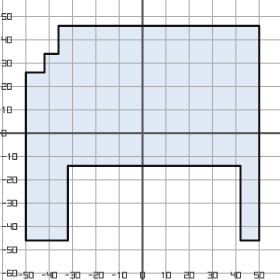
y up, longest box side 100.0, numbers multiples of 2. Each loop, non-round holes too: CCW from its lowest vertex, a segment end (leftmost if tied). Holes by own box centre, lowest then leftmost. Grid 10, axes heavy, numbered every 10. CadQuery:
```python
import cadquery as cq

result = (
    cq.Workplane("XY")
    .moveTo(-50.0, -46.0)
    .lineTo(-32.0, -46.0)
    .lineTo(-32.0, -14.0)
    .lineTo(42.0, -14.0)
    .lineTo(42.0, -46.0)
    .lineTo(50.0, -46.0)
    .lineTo(50.0, 46.0)
    .lineTo(-36.0, 46.0)
    .lineTo(-36.0, 34.0)
    .lineTo(-42.0, 34.0)
    .lineTo(-42.0, 26.0)
    .lineTo(-50.0, 26.0)
    .close()
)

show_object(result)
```